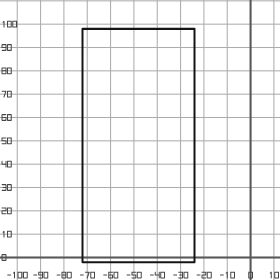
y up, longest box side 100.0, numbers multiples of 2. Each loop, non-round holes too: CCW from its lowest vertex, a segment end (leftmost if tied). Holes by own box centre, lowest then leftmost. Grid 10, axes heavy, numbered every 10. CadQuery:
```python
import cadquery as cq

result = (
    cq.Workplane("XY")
    .moveTo(-72.0, -2.0)
    .lineTo(-24.0, -2.0)
    .lineTo(-24.0, 98.0)
    .lineTo(-72.0, 98.0)
    .close()
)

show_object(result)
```